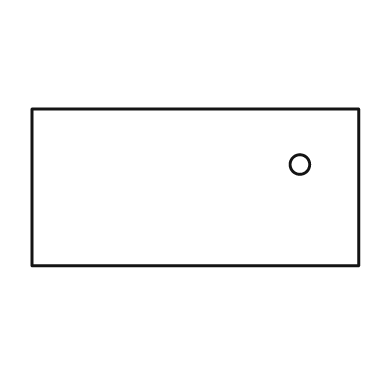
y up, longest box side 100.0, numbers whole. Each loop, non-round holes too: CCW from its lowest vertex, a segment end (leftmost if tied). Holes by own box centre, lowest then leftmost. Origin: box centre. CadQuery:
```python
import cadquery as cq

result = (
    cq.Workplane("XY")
    .moveTo(-50.0, -24.0)
    .lineTo(50.0, -24.0)
    .lineTo(50.0, 24.0)
    .lineTo(-50.0, 24.0)
    .close()
    .moveTo(32.0, 7.0)
    .circle(3.0)
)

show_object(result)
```